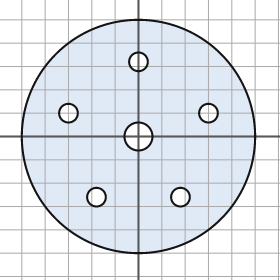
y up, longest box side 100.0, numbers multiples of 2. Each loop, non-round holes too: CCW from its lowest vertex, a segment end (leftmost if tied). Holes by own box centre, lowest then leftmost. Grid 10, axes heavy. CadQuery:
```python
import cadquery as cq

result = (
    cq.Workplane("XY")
    .moveTo(0.0, 0.0)
    .circle(50.0)
    .moveTo(-18.0, -26.0)
    .circle(4.0)
    .moveTo(18.0, -26.0)
    .circle(4.0)
    .moveTo(0.0, 0.0)
    .circle(6.0)
    .moveTo(-30.0, 10.0)
    .circle(4.0)
    .moveTo(30.0, 10.0)
    .circle(4.0)
    .moveTo(0.0, 32.0)
    .circle(4.0)
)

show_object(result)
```